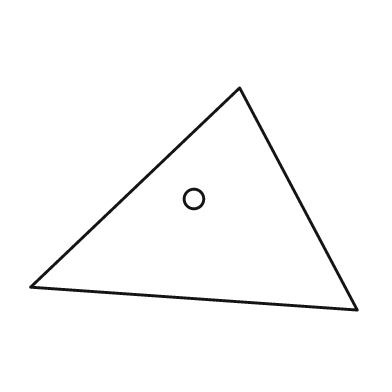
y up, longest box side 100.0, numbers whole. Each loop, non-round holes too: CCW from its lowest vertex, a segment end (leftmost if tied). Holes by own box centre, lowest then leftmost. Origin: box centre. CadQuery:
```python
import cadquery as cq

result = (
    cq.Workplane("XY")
    .moveTo(50.0, -34.0)
    .lineTo(14.0, 34.0)
    .lineTo(-50.0, -27.0)
    .close()
    .moveTo(0.0, 0.0)
    .circle(3.0)
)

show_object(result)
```